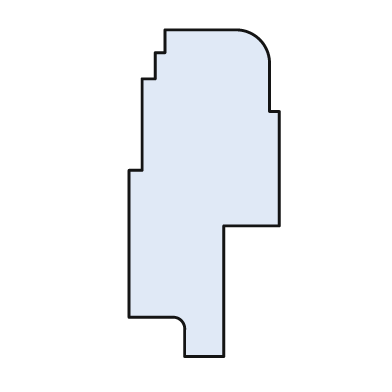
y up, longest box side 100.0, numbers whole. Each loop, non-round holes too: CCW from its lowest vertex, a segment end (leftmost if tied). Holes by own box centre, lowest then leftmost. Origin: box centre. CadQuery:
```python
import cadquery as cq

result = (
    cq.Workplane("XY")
    .moveTo(-6.0, -50.0)
    .lineTo(6.0, -50.0)
    .lineTo(6.0, -10.0)
    .lineTo(23.0, -10.0)
    .lineTo(23.0, 25.0)
    .lineTo(20.0, 25.0)
    .lineTo(20.0, 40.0)
    .threePointArc((17.0, 47.0), (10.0, 50.0))
    .lineTo(-12.0, 50.0)
    .lineTo(-12.0, 43.0)
    .lineTo(-15.0, 43.0)
    .lineTo(-15.0, 35.0)
    .lineTo(-19.0, 35.0)
    .lineTo(-19.0, 7.0)
    .lineTo(-23.0, 7.0)
    .lineTo(-23.0, -38.0)
    .lineTo(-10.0, -38.0)
    .threePointArc((-7.0, -39.0), (-6.0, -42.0))
    .close()
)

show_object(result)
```